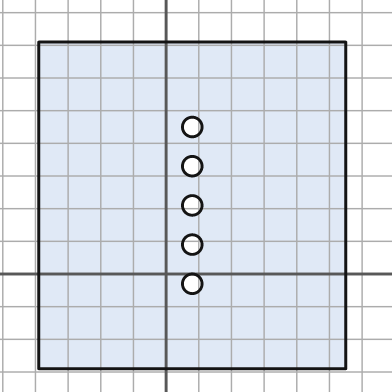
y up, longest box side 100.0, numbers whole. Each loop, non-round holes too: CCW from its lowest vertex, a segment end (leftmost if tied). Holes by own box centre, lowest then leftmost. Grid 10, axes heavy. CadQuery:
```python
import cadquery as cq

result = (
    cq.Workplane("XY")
    .moveTo(-39.0, -29.0)
    .lineTo(55.0, -29.0)
    .lineTo(55.0, 71.0)
    .lineTo(-39.0, 71.0)
    .close()
    .moveTo(8.0, -3.0)
    .circle(3.0)
    .moveTo(8.0, 9.0)
    .circle(3.0)
    .moveTo(8.0, 21.0)
    .circle(3.0)
    .moveTo(8.0, 33.0)
    .circle(3.0)
    .moveTo(8.0, 45.0)
    .circle(3.0)
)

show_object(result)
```